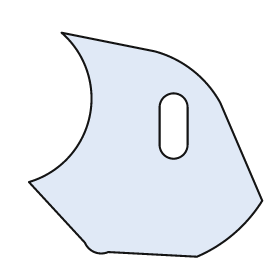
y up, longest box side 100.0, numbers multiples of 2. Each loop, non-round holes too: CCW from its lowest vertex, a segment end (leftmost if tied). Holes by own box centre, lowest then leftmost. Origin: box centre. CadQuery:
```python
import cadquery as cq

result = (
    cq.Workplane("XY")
    .moveTo(22.0, -48.0)
    .threePointArc((38.0, -38.0), (50.0, -24.0))
    .lineTo(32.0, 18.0)
    .threePointArc((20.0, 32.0), (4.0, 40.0))
    .lineTo(-36.0, 48.0)
    .threePointArc((-24.0, 12.0), (-50.0, -16.0))
    .lineTo(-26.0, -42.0)
    .threePointArc((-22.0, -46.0), (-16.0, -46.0))
    .close()
    .moveTo(6.0, 0.0)
    .threePointArc((12.0, -6.0), (18.0, 0.0))
    .lineTo(18.0, 16.0)
    .threePointArc((12.0, 22.0), (6.0, 16.0))
    .close()
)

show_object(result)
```